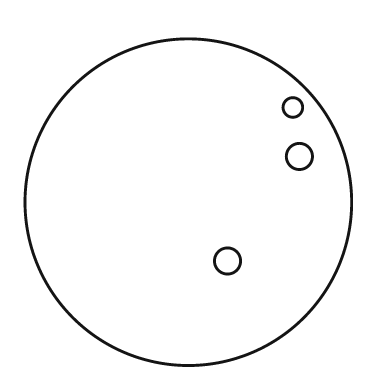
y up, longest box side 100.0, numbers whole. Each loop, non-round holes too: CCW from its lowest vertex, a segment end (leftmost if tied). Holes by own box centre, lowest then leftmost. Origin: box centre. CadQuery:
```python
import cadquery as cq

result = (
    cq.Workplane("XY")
    .moveTo(0.0, 0.0)
    .circle(50.0)
    .moveTo(12.0, -18.0)
    .circle(4.0)
    .moveTo(34.0, 14.0)
    .circle(4.0)
    .moveTo(32.0, 29.0)
    .circle(3.0)
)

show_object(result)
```